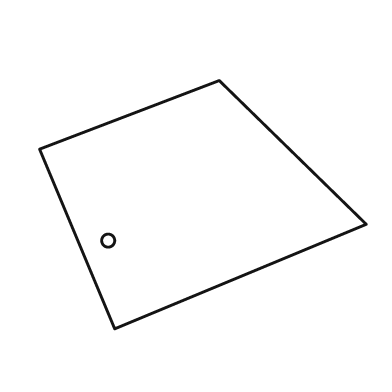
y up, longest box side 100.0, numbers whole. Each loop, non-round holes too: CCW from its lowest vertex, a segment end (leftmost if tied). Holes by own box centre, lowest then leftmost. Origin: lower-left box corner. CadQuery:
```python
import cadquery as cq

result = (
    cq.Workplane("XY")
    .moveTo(23.0, 0.0)
    .lineTo(100.0, 32.0)
    .lineTo(55.0, 76.0)
    .lineTo(0.0, 55.0)
    .close()
    .moveTo(21.0, 27.0)
    .circle(2.0)
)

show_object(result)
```